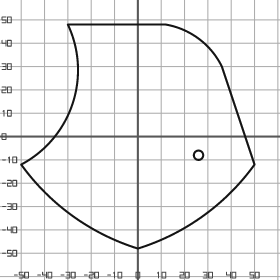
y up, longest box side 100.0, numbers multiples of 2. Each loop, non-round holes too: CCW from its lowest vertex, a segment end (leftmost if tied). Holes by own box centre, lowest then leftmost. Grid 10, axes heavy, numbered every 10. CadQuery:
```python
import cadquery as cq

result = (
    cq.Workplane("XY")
    .moveTo(0.0, -48.0)
    .threePointArc((28.0, -34.0), (50.0, -12.0))
    .lineTo(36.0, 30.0)
    .threePointArc((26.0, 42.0), (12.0, 48.0))
    .lineTo(-30.0, 48.0)
    .threePointArc((-28.0, 14.0), (-50.0, -12.0))
    .threePointArc((-28.0, -34.0), (0.0, -48.0))
    .close()
    .moveTo(26.0, -8.0)
    .circle(2.0)
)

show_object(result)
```